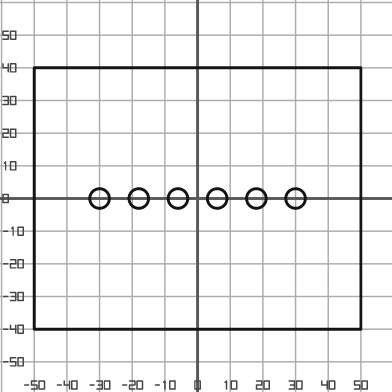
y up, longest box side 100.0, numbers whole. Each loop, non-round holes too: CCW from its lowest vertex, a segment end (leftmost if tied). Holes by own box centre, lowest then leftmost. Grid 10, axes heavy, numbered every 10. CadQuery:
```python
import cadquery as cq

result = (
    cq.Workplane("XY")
    .moveTo(-50.0, -40.0)
    .lineTo(50.0, -40.0)
    .lineTo(50.0, 40.0)
    .lineTo(-50.0, 40.0)
    .close()
    .moveTo(-30.0, 0.0)
    .circle(3.0)
    .moveTo(-18.0, 0.0)
    .circle(3.0)
    .moveTo(-6.0, 0.0)
    .circle(3.0)
    .moveTo(6.0, 0.0)
    .circle(3.0)
    .moveTo(18.0, 0.0)
    .circle(3.0)
    .moveTo(30.0, 0.0)
    .circle(3.0)
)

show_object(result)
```